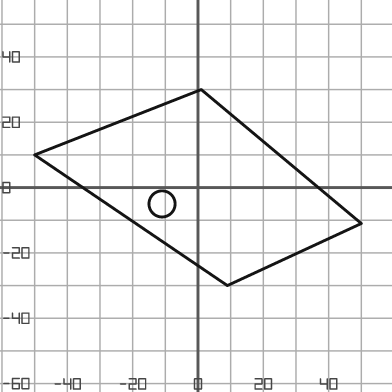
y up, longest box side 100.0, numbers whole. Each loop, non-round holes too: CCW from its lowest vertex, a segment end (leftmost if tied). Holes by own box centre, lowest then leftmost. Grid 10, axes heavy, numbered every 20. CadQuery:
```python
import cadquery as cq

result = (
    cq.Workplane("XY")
    .moveTo(9.0, -30.0)
    .lineTo(50.0, -11.0)
    .lineTo(1.0, 30.0)
    .lineTo(-50.0, 10.0)
    .close()
    .moveTo(-11.0, -5.0)
    .circle(4.0)
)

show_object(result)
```